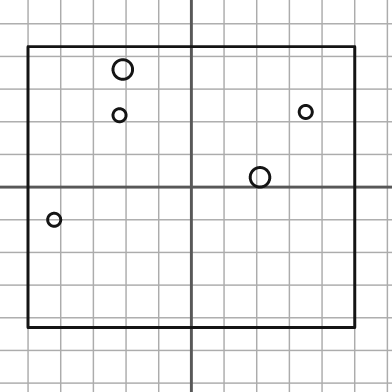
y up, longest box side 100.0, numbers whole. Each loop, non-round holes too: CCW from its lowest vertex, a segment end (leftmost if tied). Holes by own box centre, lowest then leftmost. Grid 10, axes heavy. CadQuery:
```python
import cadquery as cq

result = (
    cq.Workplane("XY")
    .moveTo(-50.0, -43.0)
    .lineTo(50.0, -43.0)
    .lineTo(50.0, 43.0)
    .lineTo(-50.0, 43.0)
    .close()
    .moveTo(-42.0, -10.0)
    .circle(2.0)
    .moveTo(21.0, 3.0)
    .circle(3.0)
    .moveTo(-22.0, 22.0)
    .circle(2.0)
    .moveTo(35.0, 23.0)
    .circle(2.0)
    .moveTo(-21.0, 36.0)
    .circle(3.0)
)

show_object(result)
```